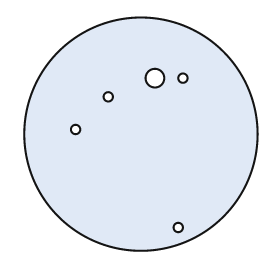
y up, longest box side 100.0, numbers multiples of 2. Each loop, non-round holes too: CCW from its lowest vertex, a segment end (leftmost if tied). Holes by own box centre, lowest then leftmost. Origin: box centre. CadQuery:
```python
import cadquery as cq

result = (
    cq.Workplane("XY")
    .moveTo(0.0, 0.0)
    .circle(50.0)
    .moveTo(16.0, -40.0)
    .circle(2.0)
    .moveTo(-28.0, 2.0)
    .circle(2.0)
    .moveTo(-14.0, 16.0)
    .circle(2.0)
    .moveTo(6.0, 24.0)
    .circle(4.0)
    .moveTo(18.0, 24.0)
    .circle(2.0)
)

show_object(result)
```